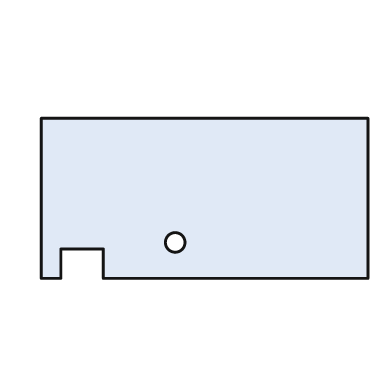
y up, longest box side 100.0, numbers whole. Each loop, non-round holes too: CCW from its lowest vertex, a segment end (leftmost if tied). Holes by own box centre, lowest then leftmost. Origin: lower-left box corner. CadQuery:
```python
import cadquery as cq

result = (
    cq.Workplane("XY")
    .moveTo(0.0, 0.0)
    .lineTo(6.0, 0.0)
    .lineTo(6.0, 9.0)
    .lineTo(19.0, 9.0)
    .lineTo(19.0, 0.0)
    .lineTo(100.0, 0.0)
    .lineTo(100.0, 49.0)
    .lineTo(0.0, 49.0)
    .close()
    .moveTo(41.0, 11.0)
    .circle(3.0)
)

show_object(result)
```